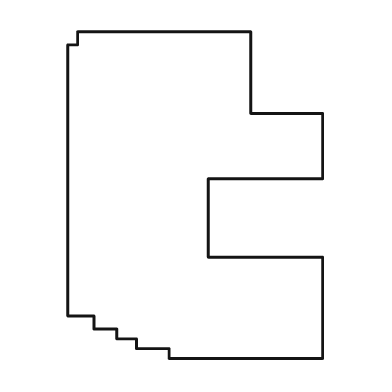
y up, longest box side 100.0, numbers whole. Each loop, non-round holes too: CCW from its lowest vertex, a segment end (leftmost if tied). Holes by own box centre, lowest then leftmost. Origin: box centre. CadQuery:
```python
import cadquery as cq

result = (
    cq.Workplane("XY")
    .moveTo(-8.0, -50.0)
    .lineTo(39.0, -50.0)
    .lineTo(39.0, -19.0)
    .lineTo(4.0, -19.0)
    .lineTo(4.0, 5.0)
    .lineTo(39.0, 5.0)
    .lineTo(39.0, 25.0)
    .lineTo(17.0, 25.0)
    .lineTo(17.0, 50.0)
    .lineTo(-36.0, 50.0)
    .lineTo(-36.0, 46.0)
    .lineTo(-39.0, 46.0)
    .lineTo(-39.0, -37.0)
    .lineTo(-31.0, -37.0)
    .lineTo(-31.0, -41.0)
    .lineTo(-24.0, -41.0)
    .lineTo(-24.0, -44.0)
    .lineTo(-18.0, -44.0)
    .lineTo(-18.0, -47.0)
    .lineTo(-8.0, -47.0)
    .close()
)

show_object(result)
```